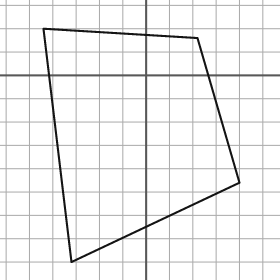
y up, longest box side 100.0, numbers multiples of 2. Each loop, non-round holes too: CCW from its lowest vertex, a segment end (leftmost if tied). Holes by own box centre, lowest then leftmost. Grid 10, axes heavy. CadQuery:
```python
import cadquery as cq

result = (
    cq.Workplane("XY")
    .moveTo(-32.0, -80.0)
    .lineTo(40.0, -46.0)
    .lineTo(22.0, 16.0)
    .lineTo(-44.0, 20.0)
    .close()
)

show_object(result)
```